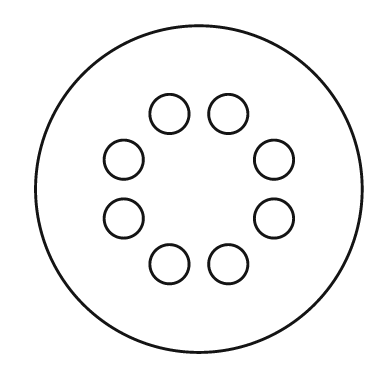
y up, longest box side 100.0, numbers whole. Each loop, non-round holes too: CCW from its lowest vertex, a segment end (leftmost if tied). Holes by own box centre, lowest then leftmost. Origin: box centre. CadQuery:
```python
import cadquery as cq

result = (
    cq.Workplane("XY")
    .moveTo(0.0, 0.0)
    .circle(50.0)
    .moveTo(-9.0, -23.0)
    .circle(6.0)
    .moveTo(9.0, -23.0)
    .circle(6.0)
    .moveTo(-23.0, -9.0)
    .circle(6.0)
    .moveTo(23.0, -9.0)
    .circle(6.0)
    .moveTo(-23.0, 9.0)
    .circle(6.0)
    .moveTo(23.0, 9.0)
    .circle(6.0)
    .moveTo(-9.0, 23.0)
    .circle(6.0)
    .moveTo(9.0, 23.0)
    .circle(6.0)
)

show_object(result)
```